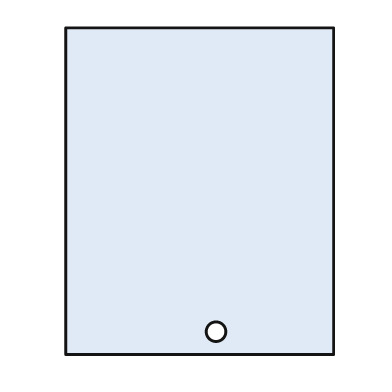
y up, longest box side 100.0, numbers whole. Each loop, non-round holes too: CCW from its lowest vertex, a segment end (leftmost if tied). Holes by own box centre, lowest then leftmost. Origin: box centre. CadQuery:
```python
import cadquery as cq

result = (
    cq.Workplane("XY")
    .moveTo(-41.0, -50.0)
    .lineTo(41.0, -50.0)
    .lineTo(41.0, 50.0)
    .lineTo(-41.0, 50.0)
    .close()
    .moveTo(5.0, -43.0)
    .circle(3.0)
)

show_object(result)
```